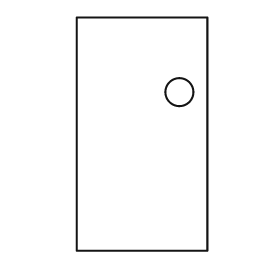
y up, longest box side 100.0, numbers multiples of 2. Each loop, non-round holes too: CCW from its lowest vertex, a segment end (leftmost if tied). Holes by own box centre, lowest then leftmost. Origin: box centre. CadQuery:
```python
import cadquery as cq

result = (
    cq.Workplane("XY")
    .moveTo(-28.0, -50.0)
    .lineTo(28.0, -50.0)
    .lineTo(28.0, 50.0)
    .lineTo(-28.0, 50.0)
    .close()
    .moveTo(16.0, 18.0)
    .circle(6.0)
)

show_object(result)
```